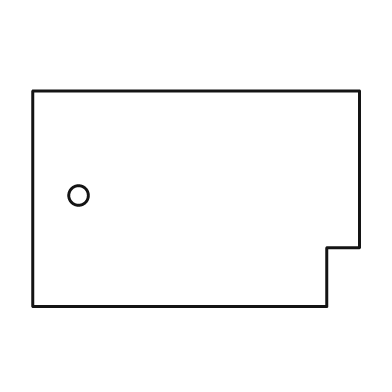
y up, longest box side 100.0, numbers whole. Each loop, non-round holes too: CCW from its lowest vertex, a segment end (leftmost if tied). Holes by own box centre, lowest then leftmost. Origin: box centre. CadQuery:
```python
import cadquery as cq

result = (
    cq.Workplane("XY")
    .moveTo(-50.0, -33.0)
    .lineTo(40.0, -33.0)
    .lineTo(40.0, -15.0)
    .lineTo(50.0, -15.0)
    .lineTo(50.0, 33.0)
    .lineTo(-50.0, 33.0)
    .close()
    .moveTo(-36.0, 1.0)
    .circle(3.0)
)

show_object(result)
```